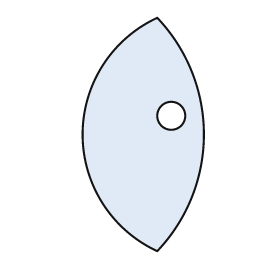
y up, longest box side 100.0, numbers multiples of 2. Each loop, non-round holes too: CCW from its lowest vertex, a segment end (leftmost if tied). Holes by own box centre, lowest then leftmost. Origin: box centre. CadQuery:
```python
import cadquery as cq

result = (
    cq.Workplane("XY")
    .moveTo(6.0, -50.0)
    .threePointArc((26.0, 0.0), (6.0, 50.0))
    .threePointArc((-26.0, 0.0), (6.0, -50.0))
    .close()
    .moveTo(12.0, 8.0)
    .circle(6.0)
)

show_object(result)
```